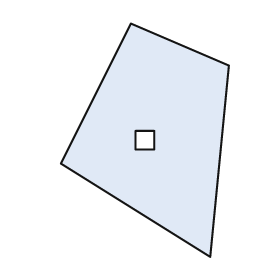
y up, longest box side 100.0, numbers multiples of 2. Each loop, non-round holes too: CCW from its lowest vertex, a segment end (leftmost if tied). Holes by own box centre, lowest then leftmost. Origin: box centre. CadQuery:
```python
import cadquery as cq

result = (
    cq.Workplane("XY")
    .moveTo(28.0, -50.0)
    .lineTo(36.0, 32.0)
    .lineTo(-6.0, 50.0)
    .lineTo(-36.0, -10.0)
    .close()
    .moveTo(-4.0, -4.0)
    .lineTo(4.0, -4.0)
    .lineTo(4.0, 4.0)
    .lineTo(-4.0, 4.0)
    .close()
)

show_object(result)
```